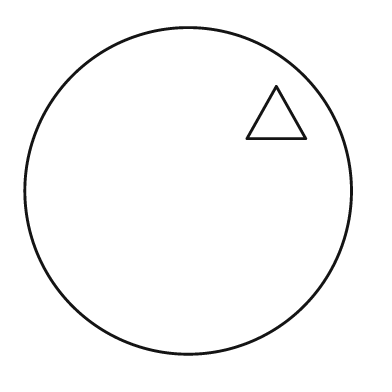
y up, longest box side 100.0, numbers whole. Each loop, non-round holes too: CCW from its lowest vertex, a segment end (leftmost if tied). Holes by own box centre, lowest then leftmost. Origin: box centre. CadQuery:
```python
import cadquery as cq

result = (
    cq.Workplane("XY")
    .moveTo(0.0, 0.0)
    .circle(50.0)
    .moveTo(18.0, 16.0)
    .lineTo(36.0, 16.0)
    .lineTo(27.0, 32.0)
    .close()
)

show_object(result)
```